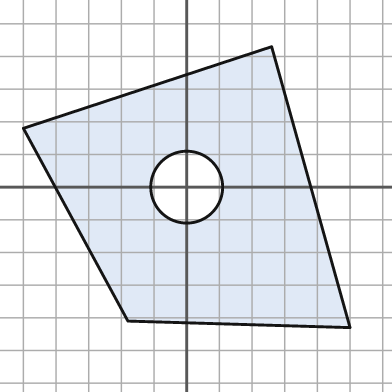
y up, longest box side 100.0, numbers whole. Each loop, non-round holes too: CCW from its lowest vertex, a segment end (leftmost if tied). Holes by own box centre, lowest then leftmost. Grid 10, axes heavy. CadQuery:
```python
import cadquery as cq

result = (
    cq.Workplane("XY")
    .moveTo(50.0, -43.0)
    .lineTo(26.0, 43.0)
    .lineTo(-50.0, 18.0)
    .lineTo(-18.0, -41.0)
    .close()
    .moveTo(0.0, 0.0)
    .circle(11.0)
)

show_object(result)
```